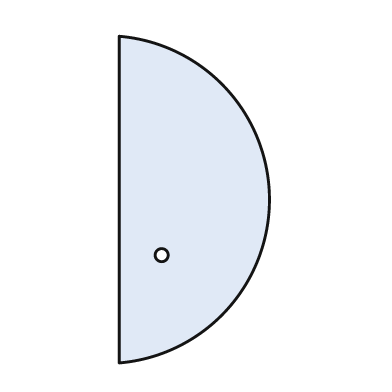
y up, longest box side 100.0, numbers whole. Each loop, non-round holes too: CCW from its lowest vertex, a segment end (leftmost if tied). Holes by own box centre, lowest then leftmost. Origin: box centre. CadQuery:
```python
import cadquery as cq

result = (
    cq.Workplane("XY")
    .moveTo(-23.0, -50.0)
    .threePointArc((23.0, 0.0), (-23.0, 50.0))
    .close()
    .moveTo(-10.0, -17.0)
    .circle(2.0)
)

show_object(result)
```